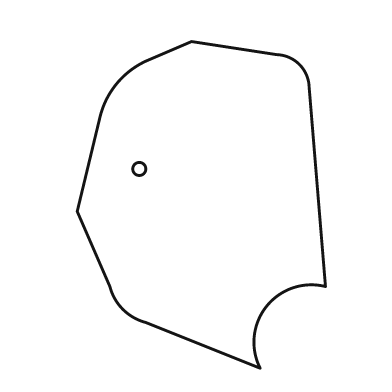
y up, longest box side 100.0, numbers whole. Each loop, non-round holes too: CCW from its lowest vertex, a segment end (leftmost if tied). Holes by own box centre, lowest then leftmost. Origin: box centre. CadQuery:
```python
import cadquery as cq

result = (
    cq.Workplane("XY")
    .moveTo(18.0, -50.0)
    .threePointArc((20.0, -31.0), (38.0, -25.0))
    .lineTo(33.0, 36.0)
    .threePointArc((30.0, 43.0), (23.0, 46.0))
    .lineTo(-3.0, 50.0)
    .lineTo(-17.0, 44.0)
    .threePointArc((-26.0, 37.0), (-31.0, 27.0))
    .lineTo(-38.0, -2.0)
    .lineTo(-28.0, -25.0)
    .threePointArc((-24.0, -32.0), (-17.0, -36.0))
    .close()
    .moveTo(-19.0, 11.0)
    .circle(2.0)
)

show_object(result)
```